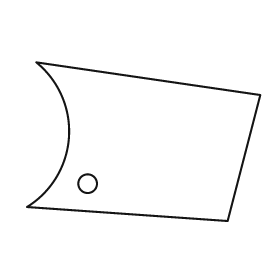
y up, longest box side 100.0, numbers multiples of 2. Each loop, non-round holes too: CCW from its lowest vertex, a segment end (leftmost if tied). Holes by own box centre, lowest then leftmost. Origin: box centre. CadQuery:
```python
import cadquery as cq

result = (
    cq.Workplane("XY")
    .moveTo(36.0, -34.0)
    .lineTo(50.0, 20.0)
    .lineTo(-46.0, 34.0)
    .threePointArc((-32.0, 2.0), (-50.0, -28.0))
    .close()
    .moveTo(-24.0, -18.0)
    .circle(4.0)
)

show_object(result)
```